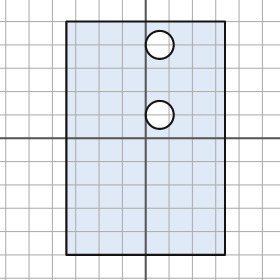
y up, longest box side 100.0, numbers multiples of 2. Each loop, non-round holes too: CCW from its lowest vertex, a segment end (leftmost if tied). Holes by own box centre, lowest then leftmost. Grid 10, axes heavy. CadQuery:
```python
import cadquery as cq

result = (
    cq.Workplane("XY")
    .moveTo(-34.0, -50.0)
    .lineTo(34.0, -50.0)
    .lineTo(34.0, 50.0)
    .lineTo(-34.0, 50.0)
    .close()
    .moveTo(6.0, 10.0)
    .circle(6.0)
    .moveTo(6.0, 40.0)
    .circle(6.0)
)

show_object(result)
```